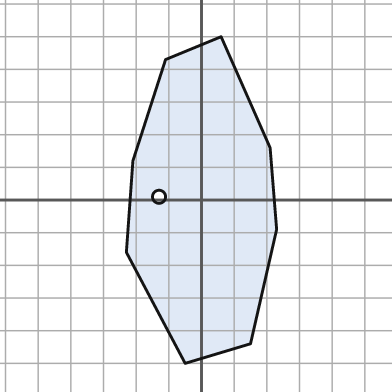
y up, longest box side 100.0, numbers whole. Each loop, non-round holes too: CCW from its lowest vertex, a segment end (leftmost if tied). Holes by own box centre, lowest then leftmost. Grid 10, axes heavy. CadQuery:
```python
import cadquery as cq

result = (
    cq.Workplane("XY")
    .moveTo(-5.0, -50.0)
    .lineTo(15.0, -44.0)
    .lineTo(23.0, -9.0)
    .lineTo(21.0, 16.0)
    .lineTo(6.0, 50.0)
    .lineTo(-11.0, 43.0)
    .lineTo(-21.0, 12.0)
    .lineTo(-23.0, -16.0)
    .close()
    .moveTo(-13.0, 1.0)
    .circle(2.0)
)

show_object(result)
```